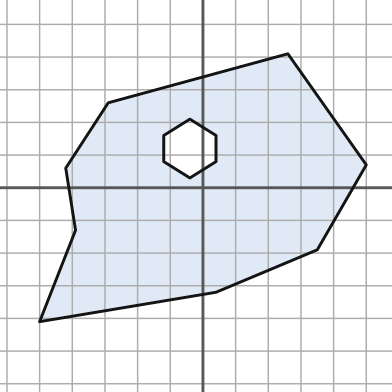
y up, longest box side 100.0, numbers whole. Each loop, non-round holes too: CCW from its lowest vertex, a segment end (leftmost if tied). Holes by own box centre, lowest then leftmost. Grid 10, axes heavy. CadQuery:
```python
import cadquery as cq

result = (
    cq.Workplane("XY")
    .moveTo(-50.0, -41.0)
    .lineTo(4.0, -32.0)
    .lineTo(35.0, -19.0)
    .lineTo(50.0, 7.0)
    .lineTo(26.0, 41.0)
    .lineTo(-29.0, 26.0)
    .lineTo(-42.0, 6.0)
    .lineTo(-39.0, -13.0)
    .close()
    .moveTo(-4.0, 3.0)
    .lineTo(4.0, 8.0)
    .lineTo(4.0, 16.0)
    .lineTo(-4.0, 21.0)
    .lineTo(-12.0, 16.0)
    .lineTo(-12.0, 8.0)
    .close()
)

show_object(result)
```